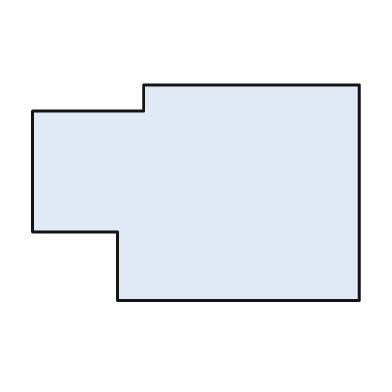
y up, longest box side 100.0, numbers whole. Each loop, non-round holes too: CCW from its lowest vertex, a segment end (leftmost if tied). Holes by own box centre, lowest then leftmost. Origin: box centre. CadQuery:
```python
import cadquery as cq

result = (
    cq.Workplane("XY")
    .moveTo(-24.0, -33.0)
    .lineTo(50.0, -33.0)
    .lineTo(50.0, 33.0)
    .lineTo(-16.0, 33.0)
    .lineTo(-16.0, 25.0)
    .lineTo(-50.0, 25.0)
    .lineTo(-50.0, -12.0)
    .lineTo(-24.0, -12.0)
    .close()
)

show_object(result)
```